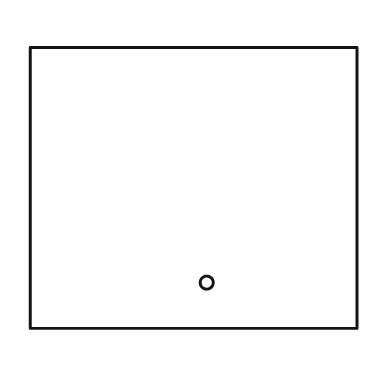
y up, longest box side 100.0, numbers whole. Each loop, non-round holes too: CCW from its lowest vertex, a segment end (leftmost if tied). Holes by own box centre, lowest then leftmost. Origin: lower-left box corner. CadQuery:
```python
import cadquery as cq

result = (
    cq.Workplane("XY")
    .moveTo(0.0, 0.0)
    .lineTo(100.0, 0.0)
    .lineTo(100.0, 86.0)
    .lineTo(0.0, 86.0)
    .close()
    .moveTo(54.0, 14.0)
    .circle(2.0)
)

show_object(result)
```